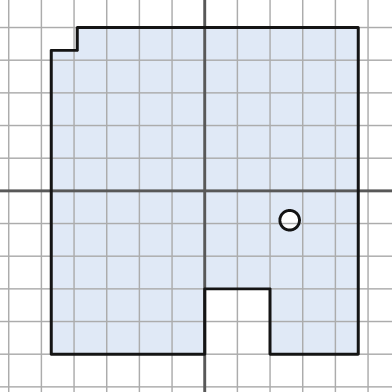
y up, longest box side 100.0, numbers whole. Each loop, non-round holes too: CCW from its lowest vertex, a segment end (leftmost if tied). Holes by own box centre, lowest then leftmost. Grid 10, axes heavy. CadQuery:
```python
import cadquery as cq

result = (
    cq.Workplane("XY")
    .moveTo(-47.0, -50.0)
    .lineTo(0.0, -50.0)
    .lineTo(0.0, -30.0)
    .lineTo(20.0, -30.0)
    .lineTo(20.0, -50.0)
    .lineTo(47.0, -50.0)
    .lineTo(47.0, 50.0)
    .lineTo(-39.0, 50.0)
    .lineTo(-39.0, 43.0)
    .lineTo(-47.0, 43.0)
    .close()
    .moveTo(26.0, -9.0)
    .circle(3.0)
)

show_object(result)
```